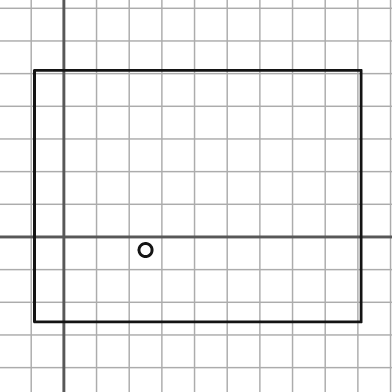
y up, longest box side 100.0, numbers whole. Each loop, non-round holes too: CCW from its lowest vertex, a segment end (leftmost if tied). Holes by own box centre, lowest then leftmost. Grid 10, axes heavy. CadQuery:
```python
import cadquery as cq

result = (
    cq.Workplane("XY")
    .moveTo(-9.0, -26.0)
    .lineTo(91.0, -26.0)
    .lineTo(91.0, 51.0)
    .lineTo(-9.0, 51.0)
    .close()
    .moveTo(25.0, -4.0)
    .circle(2.0)
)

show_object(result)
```